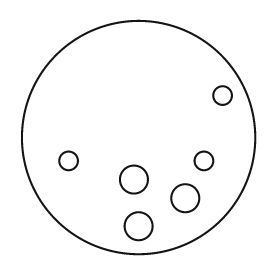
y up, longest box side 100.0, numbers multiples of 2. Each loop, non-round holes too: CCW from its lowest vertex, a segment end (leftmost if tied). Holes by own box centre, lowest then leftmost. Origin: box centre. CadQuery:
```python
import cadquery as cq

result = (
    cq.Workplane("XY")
    .moveTo(0.0, 0.0)
    .circle(50.0)
    .moveTo(0.0, -38.0)
    .circle(6.0)
    .moveTo(20.0, -26.0)
    .circle(6.0)
    .moveTo(-2.0, -18.0)
    .circle(6.0)
    .moveTo(-30.0, -10.0)
    .circle(4.0)
    .moveTo(28.0, -10.0)
    .circle(4.0)
    .moveTo(36.0, 18.0)
    .circle(4.0)
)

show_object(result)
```